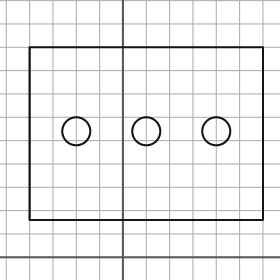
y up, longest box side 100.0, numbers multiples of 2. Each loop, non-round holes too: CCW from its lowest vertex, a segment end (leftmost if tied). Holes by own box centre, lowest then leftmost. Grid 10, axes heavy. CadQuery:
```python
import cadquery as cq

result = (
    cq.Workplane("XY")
    .moveTo(-40.0, 16.0)
    .lineTo(60.0, 16.0)
    .lineTo(60.0, 90.0)
    .lineTo(-40.0, 90.0)
    .close()
    .moveTo(-20.0, 54.0)
    .circle(6.0)
    .moveTo(10.0, 54.0)
    .circle(6.0)
    .moveTo(40.0, 54.0)
    .circle(6.0)
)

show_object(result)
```